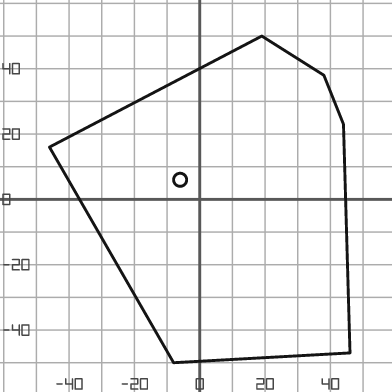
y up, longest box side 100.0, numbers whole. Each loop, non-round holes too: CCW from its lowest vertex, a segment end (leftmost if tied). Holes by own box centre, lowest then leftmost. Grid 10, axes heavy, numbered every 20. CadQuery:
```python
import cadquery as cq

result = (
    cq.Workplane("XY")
    .moveTo(-8.0, -50.0)
    .lineTo(46.0, -47.0)
    .lineTo(44.0, 23.0)
    .lineTo(38.0, 38.0)
    .lineTo(19.0, 50.0)
    .lineTo(-46.0, 16.0)
    .close()
    .moveTo(-6.0, 6.0)
    .circle(2.0)
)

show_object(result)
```